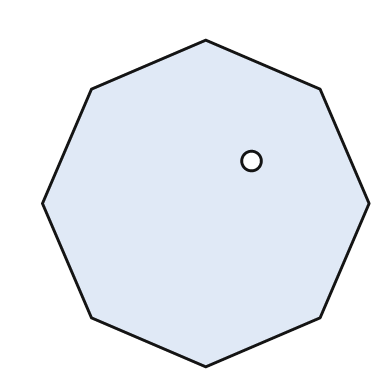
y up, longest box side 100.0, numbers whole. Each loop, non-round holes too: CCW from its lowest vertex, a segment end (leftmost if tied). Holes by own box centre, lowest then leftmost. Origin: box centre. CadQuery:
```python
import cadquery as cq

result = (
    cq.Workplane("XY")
    .moveTo(0.0, -50.0)
    .lineTo(35.0, -35.0)
    .lineTo(50.0, 0.0)
    .lineTo(35.0, 35.0)
    .lineTo(0.0, 50.0)
    .lineTo(-35.0, 35.0)
    .lineTo(-50.0, 0.0)
    .lineTo(-35.0, -35.0)
    .close()
    .moveTo(14.0, 13.0)
    .circle(3.0)
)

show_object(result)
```